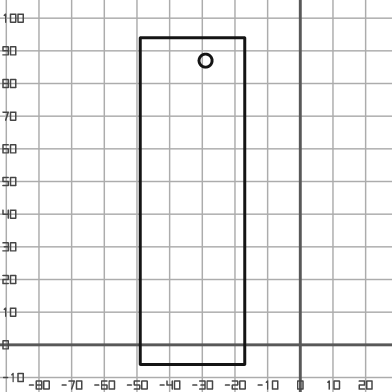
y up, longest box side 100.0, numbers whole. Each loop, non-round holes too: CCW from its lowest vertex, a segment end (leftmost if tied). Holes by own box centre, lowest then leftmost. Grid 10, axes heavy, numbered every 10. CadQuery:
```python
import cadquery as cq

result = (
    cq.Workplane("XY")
    .moveTo(-49.0, -6.0)
    .lineTo(-17.0, -6.0)
    .lineTo(-17.0, 94.0)
    .lineTo(-49.0, 94.0)
    .close()
    .moveTo(-29.0, 87.0)
    .circle(2.0)
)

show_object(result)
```